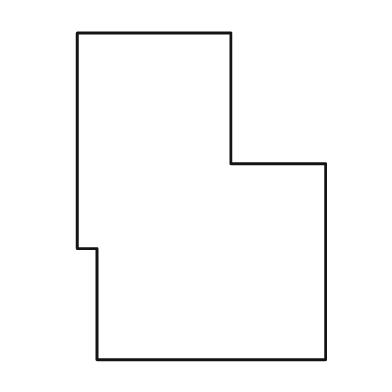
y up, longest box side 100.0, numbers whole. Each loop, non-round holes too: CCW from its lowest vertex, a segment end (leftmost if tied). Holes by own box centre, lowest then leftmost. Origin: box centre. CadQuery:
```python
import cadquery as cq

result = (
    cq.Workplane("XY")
    .moveTo(-32.0, -50.0)
    .lineTo(38.0, -50.0)
    .lineTo(38.0, 10.0)
    .lineTo(9.0, 10.0)
    .lineTo(9.0, 50.0)
    .lineTo(-38.0, 50.0)
    .lineTo(-38.0, -16.0)
    .lineTo(-32.0, -16.0)
    .close()
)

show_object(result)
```